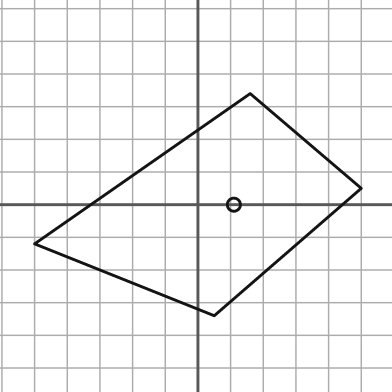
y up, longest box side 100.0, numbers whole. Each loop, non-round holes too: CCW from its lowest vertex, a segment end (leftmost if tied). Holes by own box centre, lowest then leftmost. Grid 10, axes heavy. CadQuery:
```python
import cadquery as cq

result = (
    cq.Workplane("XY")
    .moveTo(5.0, -34.0)
    .lineTo(50.0, 5.0)
    .lineTo(16.0, 34.0)
    .lineTo(-50.0, -12.0)
    .close()
    .moveTo(11.0, 0.0)
    .circle(2.0)
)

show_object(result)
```